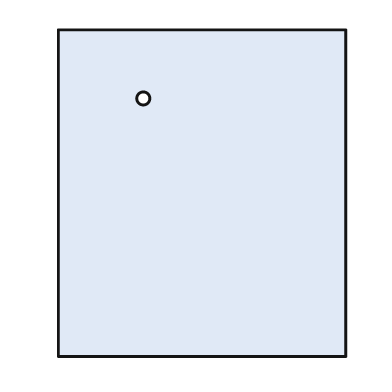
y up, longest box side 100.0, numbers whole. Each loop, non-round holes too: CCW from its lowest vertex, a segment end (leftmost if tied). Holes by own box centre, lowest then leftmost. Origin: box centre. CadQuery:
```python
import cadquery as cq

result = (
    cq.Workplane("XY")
    .moveTo(-44.0, -50.0)
    .lineTo(44.0, -50.0)
    .lineTo(44.0, 50.0)
    .lineTo(-44.0, 50.0)
    .close()
    .moveTo(-18.0, 29.0)
    .circle(2.0)
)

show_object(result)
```